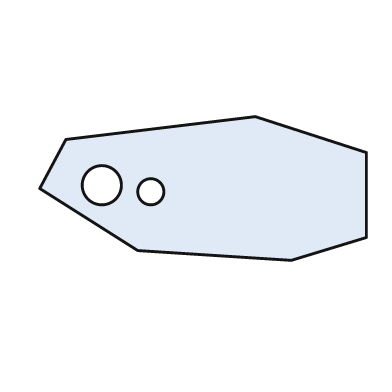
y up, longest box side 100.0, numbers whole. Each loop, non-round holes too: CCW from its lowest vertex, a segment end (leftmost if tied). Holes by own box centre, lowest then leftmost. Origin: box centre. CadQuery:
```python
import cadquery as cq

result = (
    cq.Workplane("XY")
    .moveTo(27.0, -22.0)
    .lineTo(50.0, -15.0)
    .lineTo(50.0, 11.0)
    .lineTo(16.0, 22.0)
    .lineTo(-42.0, 15.0)
    .lineTo(-50.0, 0.0)
    .lineTo(-20.0, -19.0)
    .close()
    .moveTo(-16.0, -1.0)
    .circle(4.0)
    .moveTo(-31.0, 1.0)
    .circle(6.0)
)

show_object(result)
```